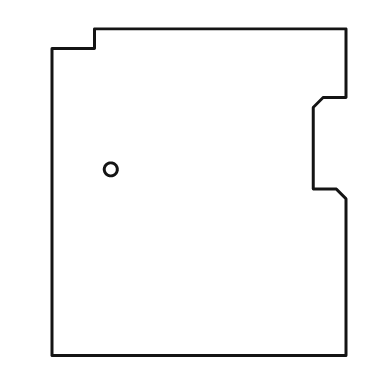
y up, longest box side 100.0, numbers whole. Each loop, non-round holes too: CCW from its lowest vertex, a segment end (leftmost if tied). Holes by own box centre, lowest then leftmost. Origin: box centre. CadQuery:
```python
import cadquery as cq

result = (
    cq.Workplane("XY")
    .moveTo(-45.0, -50.0)
    .lineTo(45.0, -50.0)
    .lineTo(45.0, -2.0)
    .lineTo(42.0, 1.0)
    .lineTo(35.0, 1.0)
    .lineTo(35.0, 26.0)
    .lineTo(38.0, 29.0)
    .lineTo(45.0, 29.0)
    .lineTo(45.0, 50.0)
    .lineTo(-32.0, 50.0)
    .lineTo(-32.0, 44.0)
    .lineTo(-45.0, 44.0)
    .close()
    .moveTo(-27.0, 7.0)
    .circle(2.0)
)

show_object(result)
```